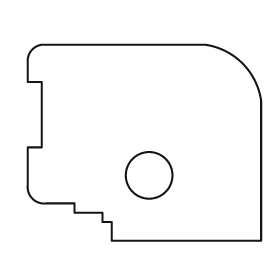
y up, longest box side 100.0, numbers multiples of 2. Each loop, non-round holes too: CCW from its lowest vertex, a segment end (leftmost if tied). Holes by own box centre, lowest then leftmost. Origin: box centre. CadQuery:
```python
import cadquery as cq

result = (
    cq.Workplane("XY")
    .moveTo(-14.0, -42.0)
    .lineTo(50.0, -42.0)
    .lineTo(50.0, 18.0)
    .threePointArc((42.0, 34.0), (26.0, 42.0))
    .lineTo(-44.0, 42.0)
    .threePointArc((-48.0, 40.0), (-50.0, 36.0))
    .lineTo(-50.0, 26.0)
    .lineTo(-44.0, 26.0)
    .lineTo(-44.0, -2.0)
    .lineTo(-50.0, -2.0)
    .lineTo(-50.0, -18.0)
    .threePointArc((-48.0, -24.0), (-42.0, -26.0))
    .lineTo(-30.0, -26.0)
    .lineTo(-30.0, -30.0)
    .lineTo(-18.0, -30.0)
    .lineTo(-18.0, -34.0)
    .lineTo(-14.0, -34.0)
    .close()
    .moveTo(2.0, -14.0)
    .circle(10.0)
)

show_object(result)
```